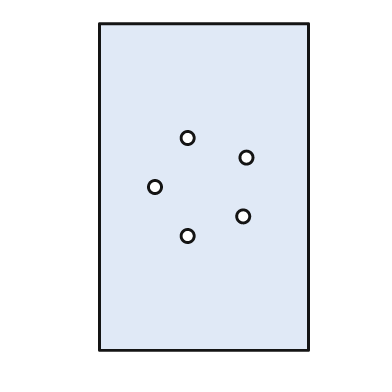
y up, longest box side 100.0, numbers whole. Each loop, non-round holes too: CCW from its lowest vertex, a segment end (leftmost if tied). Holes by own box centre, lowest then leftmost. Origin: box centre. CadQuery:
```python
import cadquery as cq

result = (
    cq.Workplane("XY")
    .moveTo(-32.0, -50.0)
    .lineTo(32.0, -50.0)
    .lineTo(32.0, 50.0)
    .lineTo(-32.0, 50.0)
    .close()
    .moveTo(-5.0, -15.0)
    .circle(2.0)
    .moveTo(12.0, -9.0)
    .circle(2.0)
    .moveTo(-15.0, 0.0)
    .circle(2.0)
    .moveTo(13.0, 9.0)
    .circle(2.0)
    .moveTo(-5.0, 15.0)
    .circle(2.0)
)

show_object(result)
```